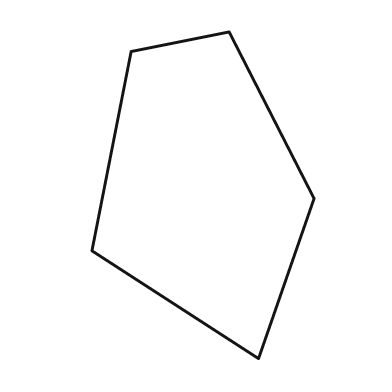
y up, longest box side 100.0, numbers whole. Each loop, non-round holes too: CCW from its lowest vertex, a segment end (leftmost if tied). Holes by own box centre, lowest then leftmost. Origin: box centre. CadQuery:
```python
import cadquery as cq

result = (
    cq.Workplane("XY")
    .moveTo(17.0, -50.0)
    .lineTo(34.0, -1.0)
    .lineTo(8.0, 50.0)
    .lineTo(-22.0, 44.0)
    .lineTo(-34.0, -17.0)
    .close()
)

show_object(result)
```